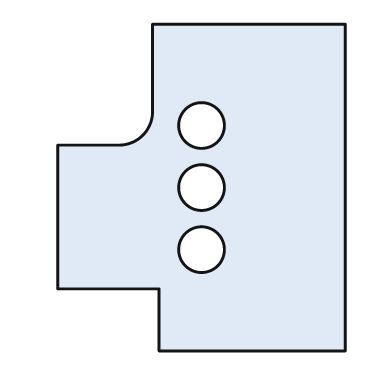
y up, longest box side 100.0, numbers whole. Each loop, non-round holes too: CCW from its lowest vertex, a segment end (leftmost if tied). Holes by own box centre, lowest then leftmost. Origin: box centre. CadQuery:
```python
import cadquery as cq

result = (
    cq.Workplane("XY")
    .moveTo(-13.0, -50.0)
    .lineTo(44.0, -50.0)
    .lineTo(44.0, 50.0)
    .lineTo(-15.0, 50.0)
    .lineTo(-15.0, 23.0)
    .threePointArc((-18.0, 16.0), (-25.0, 13.0))
    .lineTo(-44.0, 13.0)
    .lineTo(-44.0, -31.0)
    .lineTo(-13.0, -31.0)
    .close()
    .moveTo(0.0, -19.0)
    .circle(7.0)
    .moveTo(0.0, 0.0)
    .circle(7.0)
    .moveTo(0.0, 19.0)
    .circle(7.0)
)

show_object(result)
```